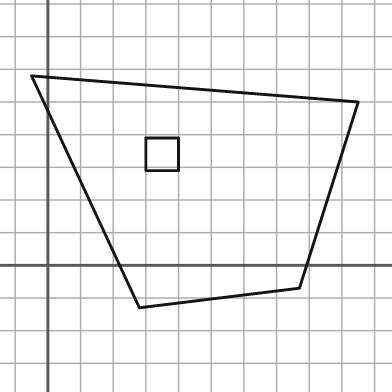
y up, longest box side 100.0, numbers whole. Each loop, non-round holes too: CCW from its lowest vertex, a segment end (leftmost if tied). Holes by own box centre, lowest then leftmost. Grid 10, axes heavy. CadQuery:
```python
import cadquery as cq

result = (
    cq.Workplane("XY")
    .moveTo(28.0, -13.0)
    .lineTo(77.0, -7.0)
    .lineTo(95.0, 50.0)
    .lineTo(-5.0, 58.0)
    .close()
    .moveTo(30.0, 29.0)
    .lineTo(40.0, 29.0)
    .lineTo(40.0, 39.0)
    .lineTo(30.0, 39.0)
    .close()
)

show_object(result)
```